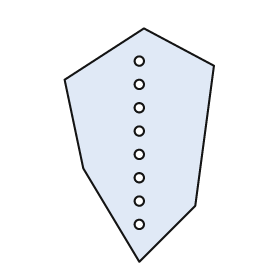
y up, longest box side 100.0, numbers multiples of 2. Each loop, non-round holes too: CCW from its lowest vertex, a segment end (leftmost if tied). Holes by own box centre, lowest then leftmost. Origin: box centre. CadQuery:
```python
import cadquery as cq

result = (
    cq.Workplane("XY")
    .moveTo(0.0, -50.0)
    .lineTo(24.0, -26.0)
    .lineTo(32.0, 34.0)
    .lineTo(2.0, 50.0)
    .lineTo(-32.0, 28.0)
    .lineTo(-24.0, -10.0)
    .close()
    .moveTo(0.0, -34.0)
    .circle(2.0)
    .moveTo(0.0, -24.0)
    .circle(2.0)
    .moveTo(0.0, -14.0)
    .circle(2.0)
    .moveTo(0.0, -4.0)
    .circle(2.0)
    .moveTo(0.0, 6.0)
    .circle(2.0)
    .moveTo(0.0, 16.0)
    .circle(2.0)
    .moveTo(0.0, 26.0)
    .circle(2.0)
    .moveTo(0.0, 36.0)
    .circle(2.0)
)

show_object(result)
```